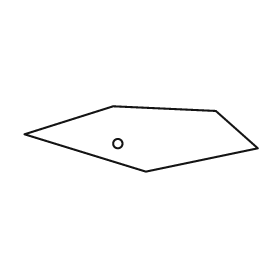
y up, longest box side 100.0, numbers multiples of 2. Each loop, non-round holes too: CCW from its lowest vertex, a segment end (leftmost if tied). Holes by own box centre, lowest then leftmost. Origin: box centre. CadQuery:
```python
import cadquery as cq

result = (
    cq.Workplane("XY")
    .moveTo(2.0, -14.0)
    .lineTo(50.0, -4.0)
    .lineTo(32.0, 12.0)
    .lineTo(-12.0, 14.0)
    .lineTo(-50.0, 2.0)
    .close()
    .moveTo(-10.0, -2.0)
    .circle(2.0)
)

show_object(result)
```